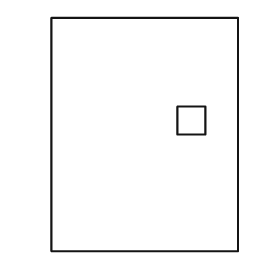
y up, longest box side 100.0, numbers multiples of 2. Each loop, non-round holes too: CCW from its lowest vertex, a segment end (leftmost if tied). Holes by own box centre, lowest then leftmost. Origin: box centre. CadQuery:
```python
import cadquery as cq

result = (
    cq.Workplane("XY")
    .moveTo(-40.0, -50.0)
    .lineTo(40.0, -50.0)
    .lineTo(40.0, 50.0)
    .lineTo(-40.0, 50.0)
    .close()
    .moveTo(14.0, 0.0)
    .lineTo(26.0, 0.0)
    .lineTo(26.0, 12.0)
    .lineTo(14.0, 12.0)
    .close()
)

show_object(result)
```